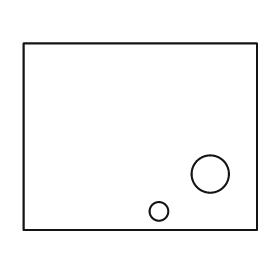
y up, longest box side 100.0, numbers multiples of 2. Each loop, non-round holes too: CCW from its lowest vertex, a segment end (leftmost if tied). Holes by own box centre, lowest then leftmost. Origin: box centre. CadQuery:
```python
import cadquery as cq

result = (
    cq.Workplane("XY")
    .moveTo(-50.0, -40.0)
    .lineTo(50.0, -40.0)
    .lineTo(50.0, 40.0)
    .lineTo(-50.0, 40.0)
    .close()
    .moveTo(8.0, -32.0)
    .circle(4.0)
    .moveTo(30.0, -16.0)
    .circle(8.0)
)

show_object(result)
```